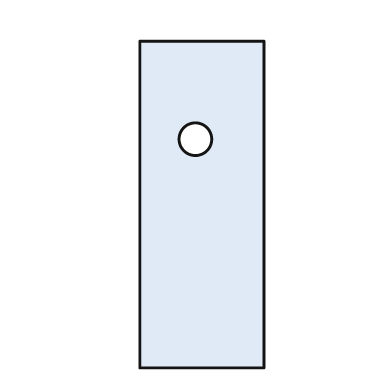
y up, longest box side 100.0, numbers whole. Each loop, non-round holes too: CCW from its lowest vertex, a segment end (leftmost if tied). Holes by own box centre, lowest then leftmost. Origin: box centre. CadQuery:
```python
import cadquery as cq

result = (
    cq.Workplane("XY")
    .moveTo(-19.0, -50.0)
    .lineTo(19.0, -50.0)
    .lineTo(19.0, 50.0)
    .lineTo(-19.0, 50.0)
    .close()
    .moveTo(-2.0, 20.0)
    .circle(5.0)
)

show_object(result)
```